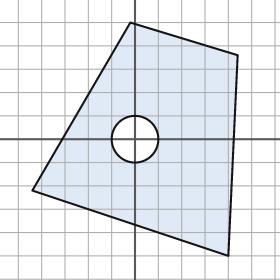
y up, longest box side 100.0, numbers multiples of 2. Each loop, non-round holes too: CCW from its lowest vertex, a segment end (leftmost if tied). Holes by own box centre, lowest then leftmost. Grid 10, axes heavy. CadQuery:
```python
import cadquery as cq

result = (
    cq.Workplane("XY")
    .moveTo(40.0, -50.0)
    .lineTo(44.0, 36.0)
    .lineTo(-2.0, 50.0)
    .lineTo(-44.0, -22.0)
    .close()
    .moveTo(0.0, 0.0)
    .circle(10.0)
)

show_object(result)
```